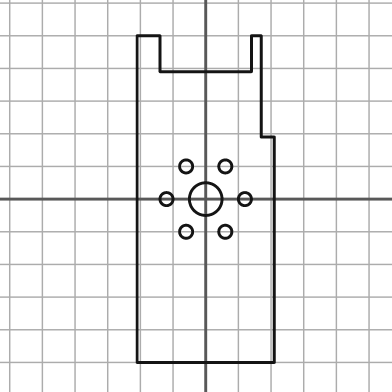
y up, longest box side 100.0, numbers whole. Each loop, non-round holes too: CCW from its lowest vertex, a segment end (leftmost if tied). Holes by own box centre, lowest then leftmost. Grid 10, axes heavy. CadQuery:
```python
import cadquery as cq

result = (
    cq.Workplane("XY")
    .moveTo(-21.0, -50.0)
    .lineTo(21.0, -50.0)
    .lineTo(21.0, 19.0)
    .lineTo(17.0, 19.0)
    .lineTo(17.0, 50.0)
    .lineTo(14.0, 50.0)
    .lineTo(14.0, 39.0)
    .lineTo(-14.0, 39.0)
    .lineTo(-14.0, 50.0)
    .lineTo(-21.0, 50.0)
    .close()
    .moveTo(-6.0, -10.0)
    .circle(2.0)
    .moveTo(6.0, -10.0)
    .circle(2.0)
    .moveTo(-12.0, 0.0)
    .circle(2.0)
    .moveTo(0.0, 0.0)
    .circle(5.0)
    .moveTo(12.0, 0.0)
    .circle(2.0)
    .moveTo(-6.0, 10.0)
    .circle(2.0)
    .moveTo(6.0, 10.0)
    .circle(2.0)
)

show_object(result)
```